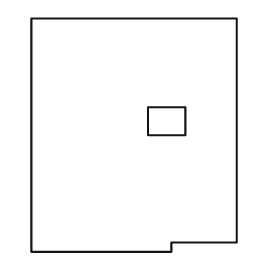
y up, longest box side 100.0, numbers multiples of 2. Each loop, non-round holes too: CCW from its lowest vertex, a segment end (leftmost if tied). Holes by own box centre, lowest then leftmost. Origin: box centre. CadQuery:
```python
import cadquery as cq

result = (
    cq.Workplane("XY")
    .moveTo(-44.0, -50.0)
    .lineTo(16.0, -50.0)
    .lineTo(16.0, -46.0)
    .lineTo(44.0, -46.0)
    .lineTo(44.0, 50.0)
    .lineTo(-44.0, 50.0)
    .close()
    .moveTo(6.0, 0.0)
    .lineTo(22.0, 0.0)
    .lineTo(22.0, 12.0)
    .lineTo(6.0, 12.0)
    .close()
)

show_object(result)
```